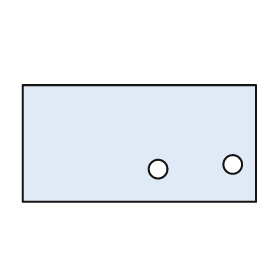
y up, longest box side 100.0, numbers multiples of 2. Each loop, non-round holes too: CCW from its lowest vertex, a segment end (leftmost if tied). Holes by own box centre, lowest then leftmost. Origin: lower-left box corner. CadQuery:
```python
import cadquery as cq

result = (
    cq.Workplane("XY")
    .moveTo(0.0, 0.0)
    .lineTo(100.0, 0.0)
    .lineTo(100.0, 50.0)
    .lineTo(0.0, 50.0)
    .close()
    .moveTo(58.0, 14.0)
    .circle(4.0)
    .moveTo(90.0, 16.0)
    .circle(4.0)
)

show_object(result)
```